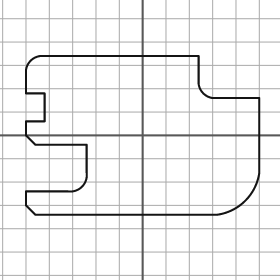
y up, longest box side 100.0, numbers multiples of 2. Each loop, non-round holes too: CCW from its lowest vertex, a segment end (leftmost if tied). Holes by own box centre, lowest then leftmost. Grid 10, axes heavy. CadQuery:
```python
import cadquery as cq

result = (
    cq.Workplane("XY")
    .moveTo(-46.0, -34.0)
    .lineTo(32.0, -34.0)
    .threePointArc((44.0, -28.0), (50.0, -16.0))
    .lineTo(50.0, 16.0)
    .lineTo(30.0, 16.0)
    .threePointArc((26.0, 18.0), (24.0, 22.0))
    .lineTo(24.0, 34.0)
    .lineTo(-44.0, 34.0)
    .threePointArc((-48.0, 32.0), (-50.0, 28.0))
    .lineTo(-50.0, 18.0)
    .lineTo(-42.0, 18.0)
    .lineTo(-42.0, 6.0)
    .lineTo(-50.0, 6.0)
    .lineTo(-50.0, 0.0)
    .lineTo(-46.0, -4.0)
    .lineTo(-24.0, -4.0)
    .lineTo(-24.0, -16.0)
    .threePointArc((-26.0, -22.0), (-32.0, -24.0))
    .lineTo(-50.0, -24.0)
    .lineTo(-50.0, -30.0)
    .close()
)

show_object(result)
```